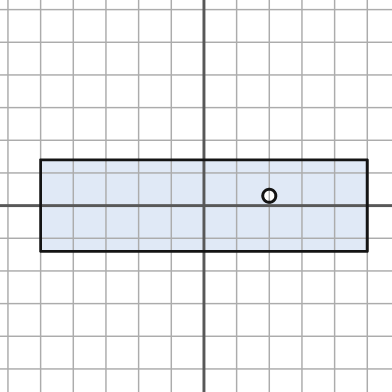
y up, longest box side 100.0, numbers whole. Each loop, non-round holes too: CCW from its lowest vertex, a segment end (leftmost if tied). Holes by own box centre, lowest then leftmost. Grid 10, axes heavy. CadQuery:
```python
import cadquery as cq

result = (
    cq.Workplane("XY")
    .moveTo(-50.0, -14.0)
    .lineTo(50.0, -14.0)
    .lineTo(50.0, 14.0)
    .lineTo(-50.0, 14.0)
    .close()
    .moveTo(20.0, 3.0)
    .circle(2.0)
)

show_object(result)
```